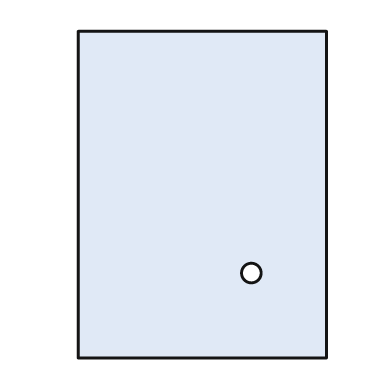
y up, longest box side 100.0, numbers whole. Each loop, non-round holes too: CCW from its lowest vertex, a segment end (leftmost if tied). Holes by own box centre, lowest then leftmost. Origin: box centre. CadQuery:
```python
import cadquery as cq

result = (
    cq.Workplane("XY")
    .moveTo(-38.0, -50.0)
    .lineTo(38.0, -50.0)
    .lineTo(38.0, 50.0)
    .lineTo(-38.0, 50.0)
    .close()
    .moveTo(15.0, -24.0)
    .circle(3.0)
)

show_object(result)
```